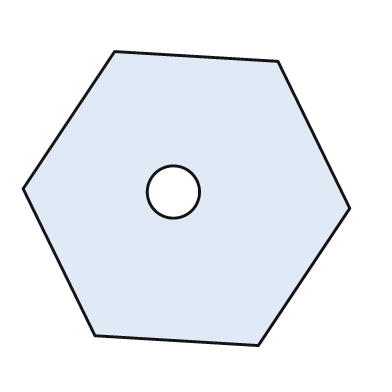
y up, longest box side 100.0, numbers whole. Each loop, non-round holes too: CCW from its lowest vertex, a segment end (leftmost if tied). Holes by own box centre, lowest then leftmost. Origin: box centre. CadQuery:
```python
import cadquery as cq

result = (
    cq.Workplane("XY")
    .moveTo(22.0, -45.0)
    .lineTo(50.0, -3.0)
    .lineTo(28.0, 42.0)
    .lineTo(-22.0, 45.0)
    .lineTo(-50.0, 3.0)
    .lineTo(-28.0, -42.0)
    .close()
    .moveTo(-4.0, 2.0)
    .circle(8.0)
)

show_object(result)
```